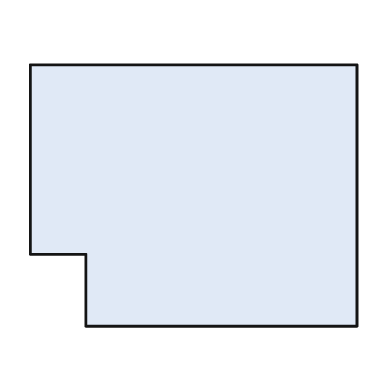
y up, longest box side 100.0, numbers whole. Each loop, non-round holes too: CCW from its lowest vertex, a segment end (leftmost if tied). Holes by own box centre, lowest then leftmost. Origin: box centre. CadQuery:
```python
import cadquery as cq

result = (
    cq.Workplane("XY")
    .moveTo(-33.0, -40.0)
    .lineTo(50.0, -40.0)
    .lineTo(50.0, 40.0)
    .lineTo(-50.0, 40.0)
    .lineTo(-50.0, -18.0)
    .lineTo(-33.0, -18.0)
    .close()
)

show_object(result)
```